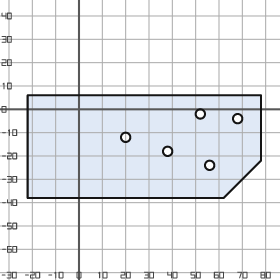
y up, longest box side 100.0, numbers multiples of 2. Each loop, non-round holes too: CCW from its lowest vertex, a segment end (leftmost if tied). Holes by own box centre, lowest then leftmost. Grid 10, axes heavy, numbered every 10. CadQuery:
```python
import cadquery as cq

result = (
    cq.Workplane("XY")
    .moveTo(-22.0, -38.0)
    .lineTo(62.0, -38.0)
    .lineTo(78.0, -22.0)
    .lineTo(78.0, 6.0)
    .lineTo(-22.0, 6.0)
    .close()
    .moveTo(56.0, -24.0)
    .circle(2.0)
    .moveTo(38.0, -18.0)
    .circle(2.0)
    .moveTo(20.0, -12.0)
    .circle(2.0)
    .moveTo(68.0, -4.0)
    .circle(2.0)
    .moveTo(52.0, -2.0)
    .circle(2.0)
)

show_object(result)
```